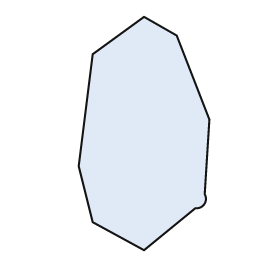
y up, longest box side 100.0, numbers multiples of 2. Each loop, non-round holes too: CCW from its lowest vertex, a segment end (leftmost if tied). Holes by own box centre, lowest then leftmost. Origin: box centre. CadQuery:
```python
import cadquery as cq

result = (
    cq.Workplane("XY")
    .moveTo(0.0, -50.0)
    .lineTo(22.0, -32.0)
    .threePointArc((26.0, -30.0), (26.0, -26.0))
    .lineTo(28.0, 6.0)
    .lineTo(14.0, 42.0)
    .lineTo(0.0, 50.0)
    .lineTo(-22.0, 34.0)
    .lineTo(-28.0, -14.0)
    .lineTo(-22.0, -38.0)
    .close()
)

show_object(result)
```